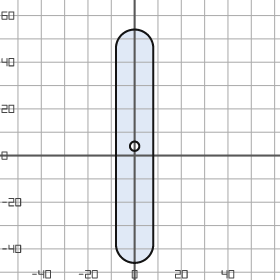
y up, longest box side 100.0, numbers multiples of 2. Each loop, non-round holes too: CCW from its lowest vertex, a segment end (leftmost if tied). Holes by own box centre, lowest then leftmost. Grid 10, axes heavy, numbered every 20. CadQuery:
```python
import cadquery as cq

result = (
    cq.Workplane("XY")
    .moveTo(-8.0, -38.0)
    .threePointArc((0.0, -46.0), (8.0, -38.0))
    .lineTo(8.0, 46.0)
    .threePointArc((0.0, 54.0), (-8.0, 46.0))
    .close()
    .moveTo(0.0, 4.0)
    .circle(2.0)
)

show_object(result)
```